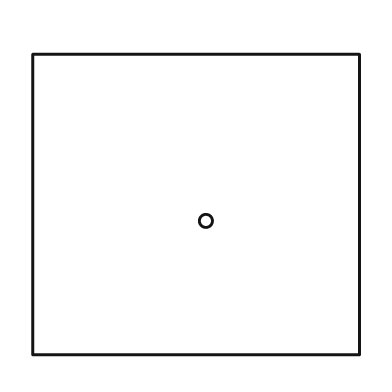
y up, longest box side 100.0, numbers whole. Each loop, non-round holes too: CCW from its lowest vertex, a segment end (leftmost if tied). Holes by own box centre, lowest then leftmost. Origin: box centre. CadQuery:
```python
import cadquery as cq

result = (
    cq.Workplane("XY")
    .moveTo(-50.0, -46.0)
    .lineTo(50.0, -46.0)
    .lineTo(50.0, 46.0)
    .lineTo(-50.0, 46.0)
    .close()
    .moveTo(3.0, -5.0)
    .circle(2.0)
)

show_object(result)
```